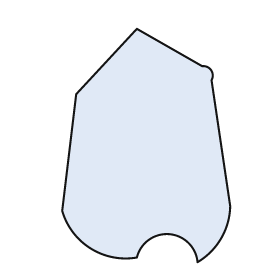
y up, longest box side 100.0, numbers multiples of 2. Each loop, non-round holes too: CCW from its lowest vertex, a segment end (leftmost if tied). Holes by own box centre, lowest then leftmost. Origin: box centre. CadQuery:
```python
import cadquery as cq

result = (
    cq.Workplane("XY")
    .moveTo(22.0, -50.0)
    .threePointArc((32.0, -40.0), (36.0, -26.0))
    .lineTo(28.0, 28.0)
    .threePointArc((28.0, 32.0), (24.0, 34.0))
    .lineTo(-4.0, 50.0)
    .lineTo(-30.0, 22.0)
    .lineTo(-36.0, -28.0)
    .threePointArc((-24.0, -44.0), (-4.0, -48.0))
    .threePointArc((10.0, -38.0), (22.0, -50.0))
    .close()
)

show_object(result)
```